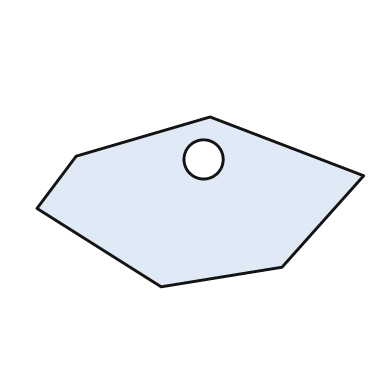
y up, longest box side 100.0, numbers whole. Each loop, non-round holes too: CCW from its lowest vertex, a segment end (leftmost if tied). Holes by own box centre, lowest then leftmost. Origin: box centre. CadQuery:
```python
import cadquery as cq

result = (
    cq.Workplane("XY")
    .moveTo(-12.0, -26.0)
    .lineTo(25.0, -20.0)
    .lineTo(50.0, 8.0)
    .lineTo(3.0, 26.0)
    .lineTo(-38.0, 14.0)
    .lineTo(-50.0, -2.0)
    .close()
    .moveTo(1.0, 13.0)
    .circle(6.0)
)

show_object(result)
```